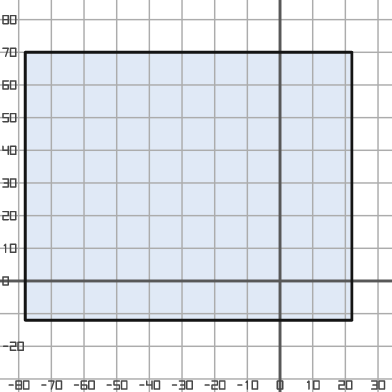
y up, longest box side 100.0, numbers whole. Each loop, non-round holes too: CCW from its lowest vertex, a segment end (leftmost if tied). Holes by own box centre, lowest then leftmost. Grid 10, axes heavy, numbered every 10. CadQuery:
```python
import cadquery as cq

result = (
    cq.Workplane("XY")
    .moveTo(-78.0, -12.0)
    .lineTo(22.0, -12.0)
    .lineTo(22.0, 70.0)
    .lineTo(-78.0, 70.0)
    .close()
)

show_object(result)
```